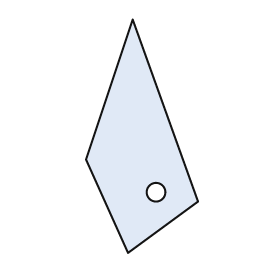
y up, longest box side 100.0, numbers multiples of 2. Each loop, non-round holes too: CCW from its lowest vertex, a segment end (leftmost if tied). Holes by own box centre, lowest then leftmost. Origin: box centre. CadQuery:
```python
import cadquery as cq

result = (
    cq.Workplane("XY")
    .moveTo(-6.0, -50.0)
    .lineTo(24.0, -28.0)
    .lineTo(-4.0, 50.0)
    .lineTo(-24.0, -10.0)
    .close()
    .moveTo(6.0, -24.0)
    .circle(4.0)
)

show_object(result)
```